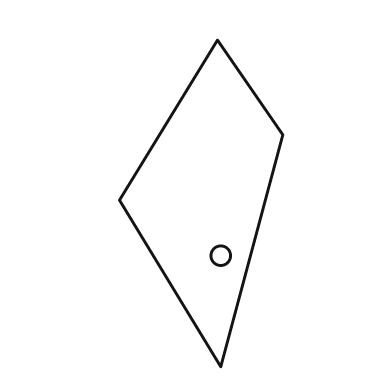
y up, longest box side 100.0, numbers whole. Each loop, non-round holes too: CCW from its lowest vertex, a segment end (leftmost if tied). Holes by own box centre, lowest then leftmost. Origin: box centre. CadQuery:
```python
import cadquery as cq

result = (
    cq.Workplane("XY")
    .moveTo(6.0, -50.0)
    .lineTo(25.0, 21.0)
    .lineTo(5.0, 50.0)
    .lineTo(-25.0, 1.0)
    .close()
    .moveTo(6.0, -16.0)
    .circle(3.0)
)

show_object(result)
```